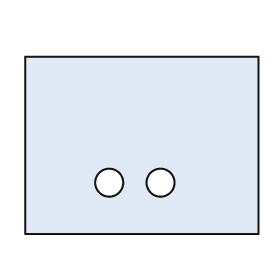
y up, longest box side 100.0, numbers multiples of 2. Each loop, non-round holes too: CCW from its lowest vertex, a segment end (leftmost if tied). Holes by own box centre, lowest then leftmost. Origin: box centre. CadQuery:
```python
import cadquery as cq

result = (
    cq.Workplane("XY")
    .moveTo(-50.0, -38.0)
    .lineTo(50.0, -38.0)
    .lineTo(50.0, 38.0)
    .lineTo(-50.0, 38.0)
    .close()
    .moveTo(-14.0, -16.0)
    .circle(6.0)
    .moveTo(8.0, -16.0)
    .circle(6.0)
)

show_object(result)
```